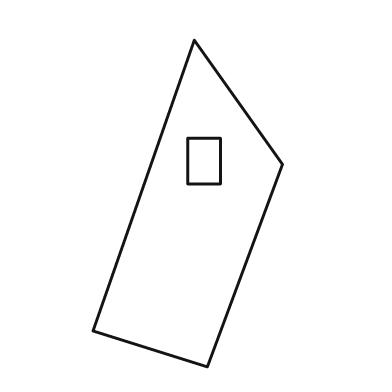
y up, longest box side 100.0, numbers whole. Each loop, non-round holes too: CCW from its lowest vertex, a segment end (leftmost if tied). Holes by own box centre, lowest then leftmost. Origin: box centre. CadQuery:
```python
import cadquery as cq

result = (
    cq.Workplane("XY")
    .moveTo(6.0, -50.0)
    .lineTo(29.0, 12.0)
    .lineTo(2.0, 50.0)
    .lineTo(-29.0, -39.0)
    .close()
    .moveTo(0.0, 6.0)
    .lineTo(10.0, 6.0)
    .lineTo(10.0, 20.0)
    .lineTo(0.0, 20.0)
    .close()
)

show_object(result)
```